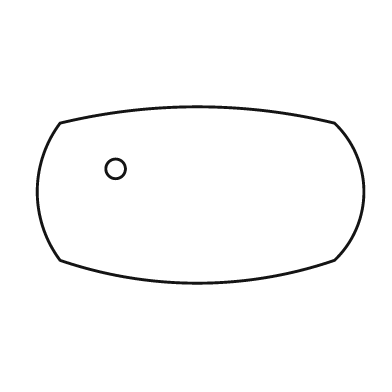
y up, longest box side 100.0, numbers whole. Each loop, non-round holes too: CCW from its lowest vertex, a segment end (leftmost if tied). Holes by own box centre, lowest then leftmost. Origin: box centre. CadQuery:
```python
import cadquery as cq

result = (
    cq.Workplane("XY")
    .moveTo(-43.0, -20.0)
    .threePointArc((-1.0, -27.0), (41.0, -20.0))
    .threePointArc((50.0, 1.0), (41.0, 22.0))
    .threePointArc((-1.0, 27.0), (-43.0, 22.0))
    .threePointArc((-50.0, 1.0), (-43.0, -20.0))
    .close()
    .moveTo(-26.0, 8.0)
    .circle(3.0)
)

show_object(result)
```